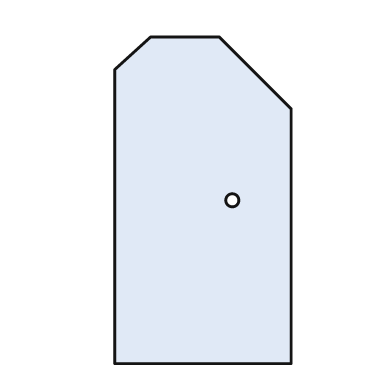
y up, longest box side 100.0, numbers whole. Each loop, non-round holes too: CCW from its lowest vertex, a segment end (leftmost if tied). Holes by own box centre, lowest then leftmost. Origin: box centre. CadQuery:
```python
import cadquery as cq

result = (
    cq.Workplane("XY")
    .moveTo(-27.0, -50.0)
    .lineTo(27.0, -50.0)
    .lineTo(27.0, 28.0)
    .lineTo(5.0, 50.0)
    .lineTo(-16.0, 50.0)
    .lineTo(-27.0, 40.0)
    .close()
    .moveTo(9.0, 0.0)
    .circle(2.0)
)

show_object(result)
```